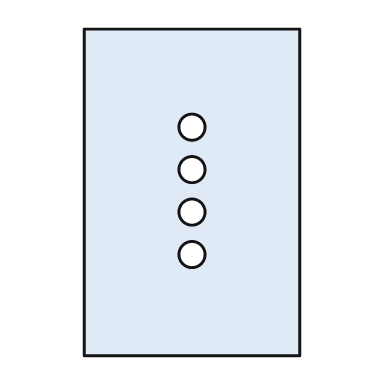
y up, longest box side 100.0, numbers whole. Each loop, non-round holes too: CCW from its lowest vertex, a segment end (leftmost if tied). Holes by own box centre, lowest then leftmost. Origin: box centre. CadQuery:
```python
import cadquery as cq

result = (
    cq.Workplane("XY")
    .moveTo(-33.0, -50.0)
    .lineTo(33.0, -50.0)
    .lineTo(33.0, 50.0)
    .lineTo(-33.0, 50.0)
    .close()
    .moveTo(0.0, -19.0)
    .circle(4.0)
    .moveTo(0.0, -6.0)
    .circle(4.0)
    .moveTo(0.0, 7.0)
    .circle(4.0)
    .moveTo(0.0, 20.0)
    .circle(4.0)
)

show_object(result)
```